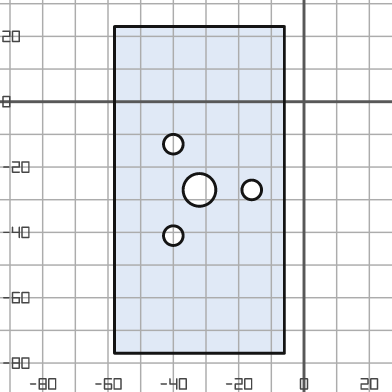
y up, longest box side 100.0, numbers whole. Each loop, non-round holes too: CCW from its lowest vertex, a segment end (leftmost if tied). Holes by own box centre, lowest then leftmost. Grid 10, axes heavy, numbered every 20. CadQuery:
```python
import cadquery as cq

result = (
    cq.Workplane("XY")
    .moveTo(-58.0, -77.0)
    .lineTo(-6.0, -77.0)
    .lineTo(-6.0, 23.0)
    .lineTo(-58.0, 23.0)
    .close()
    .moveTo(-40.0, -41.0)
    .circle(3.0)
    .moveTo(-32.0, -27.0)
    .circle(5.0)
    .moveTo(-16.0, -27.0)
    .circle(3.0)
    .moveTo(-40.0, -13.0)
    .circle(3.0)
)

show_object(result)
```